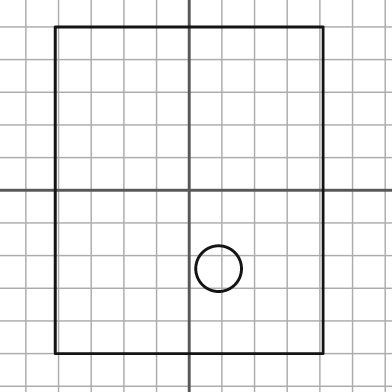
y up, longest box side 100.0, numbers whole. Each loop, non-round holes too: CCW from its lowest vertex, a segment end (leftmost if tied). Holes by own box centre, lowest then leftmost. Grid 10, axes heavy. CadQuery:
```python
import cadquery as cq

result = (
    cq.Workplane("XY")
    .moveTo(-41.0, -50.0)
    .lineTo(41.0, -50.0)
    .lineTo(41.0, 50.0)
    .lineTo(-41.0, 50.0)
    .close()
    .moveTo(9.0, -24.0)
    .circle(7.0)
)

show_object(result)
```